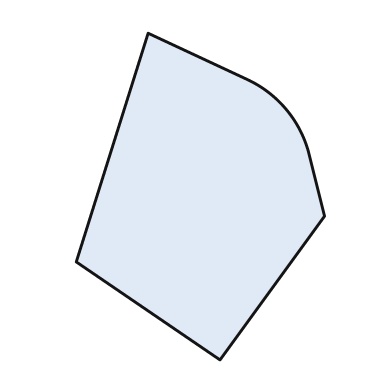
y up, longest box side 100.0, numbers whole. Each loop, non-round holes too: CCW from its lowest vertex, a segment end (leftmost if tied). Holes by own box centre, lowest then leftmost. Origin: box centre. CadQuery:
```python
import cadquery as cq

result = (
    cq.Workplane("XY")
    .moveTo(6.0, -50.0)
    .lineTo(38.0, -6.0)
    .lineTo(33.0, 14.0)
    .threePointArc((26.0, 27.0), (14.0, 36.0))
    .lineTo(-16.0, 50.0)
    .lineTo(-38.0, -20.0)
    .close()
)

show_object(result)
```